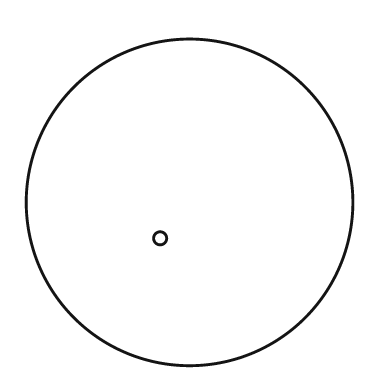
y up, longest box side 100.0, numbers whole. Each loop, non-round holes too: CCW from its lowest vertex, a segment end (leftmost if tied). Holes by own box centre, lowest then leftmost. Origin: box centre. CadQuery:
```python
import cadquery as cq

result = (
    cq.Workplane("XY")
    .moveTo(0.0, 0.0)
    .circle(50.0)
    .moveTo(-9.0, -11.0)
    .circle(2.0)
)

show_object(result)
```